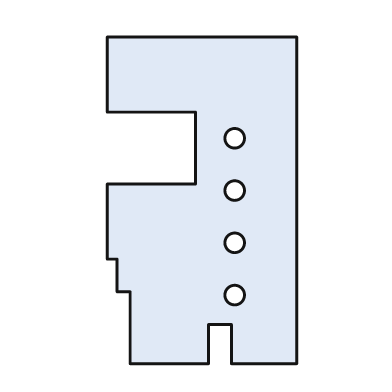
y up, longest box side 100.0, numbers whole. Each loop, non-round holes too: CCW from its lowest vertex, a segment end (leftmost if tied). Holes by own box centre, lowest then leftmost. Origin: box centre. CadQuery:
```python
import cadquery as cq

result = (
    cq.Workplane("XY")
    .moveTo(-22.0, -50.0)
    .lineTo(2.0, -50.0)
    .lineTo(2.0, -38.0)
    .lineTo(9.0, -38.0)
    .lineTo(9.0, -50.0)
    .lineTo(29.0, -50.0)
    .lineTo(29.0, 50.0)
    .lineTo(-29.0, 50.0)
    .lineTo(-29.0, 27.0)
    .lineTo(-2.0, 27.0)
    .lineTo(-2.0, 5.0)
    .lineTo(-29.0, 5.0)
    .lineTo(-29.0, -18.0)
    .lineTo(-26.0, -18.0)
    .lineTo(-26.0, -28.0)
    .lineTo(-22.0, -28.0)
    .close()
    .moveTo(10.0, -29.0)
    .circle(3.0)
    .moveTo(10.0, -13.0)
    .circle(3.0)
    .moveTo(10.0, 3.0)
    .circle(3.0)
    .moveTo(10.0, 19.0)
    .circle(3.0)
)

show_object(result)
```